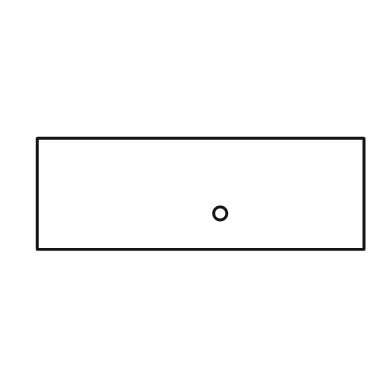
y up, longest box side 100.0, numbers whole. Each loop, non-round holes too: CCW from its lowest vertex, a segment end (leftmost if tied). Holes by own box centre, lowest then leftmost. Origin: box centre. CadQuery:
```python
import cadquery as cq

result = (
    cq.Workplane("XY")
    .moveTo(-50.0, -17.0)
    .lineTo(50.0, -17.0)
    .lineTo(50.0, 17.0)
    .lineTo(-50.0, 17.0)
    .close()
    .moveTo(6.0, -6.0)
    .circle(2.0)
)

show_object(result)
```